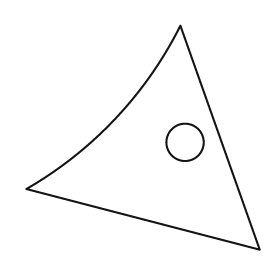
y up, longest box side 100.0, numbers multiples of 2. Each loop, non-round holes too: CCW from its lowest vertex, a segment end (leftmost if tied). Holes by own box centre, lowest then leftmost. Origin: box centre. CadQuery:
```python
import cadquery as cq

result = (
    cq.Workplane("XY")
    .moveTo(50.0, -48.0)
    .lineTo(16.0, 48.0)
    .threePointArc((-12.0, 8.0), (-50.0, -22.0))
    .close()
    .moveTo(18.0, -2.0)
    .circle(8.0)
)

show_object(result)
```